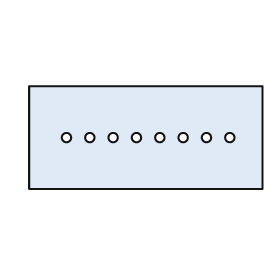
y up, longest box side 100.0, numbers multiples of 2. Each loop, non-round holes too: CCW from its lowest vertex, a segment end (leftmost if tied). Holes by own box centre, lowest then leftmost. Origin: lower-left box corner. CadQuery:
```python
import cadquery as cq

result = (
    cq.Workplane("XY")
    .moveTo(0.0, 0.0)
    .lineTo(100.0, 0.0)
    .lineTo(100.0, 44.0)
    .lineTo(0.0, 44.0)
    .close()
    .moveTo(16.0, 22.0)
    .circle(2.0)
    .moveTo(26.0, 22.0)
    .circle(2.0)
    .moveTo(36.0, 22.0)
    .circle(2.0)
    .moveTo(46.0, 22.0)
    .circle(2.0)
    .moveTo(56.0, 22.0)
    .circle(2.0)
    .moveTo(66.0, 22.0)
    .circle(2.0)
    .moveTo(76.0, 22.0)
    .circle(2.0)
    .moveTo(86.0, 22.0)
    .circle(2.0)
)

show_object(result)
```